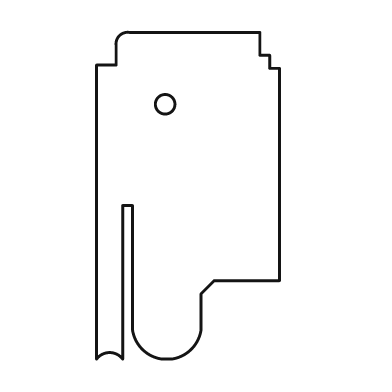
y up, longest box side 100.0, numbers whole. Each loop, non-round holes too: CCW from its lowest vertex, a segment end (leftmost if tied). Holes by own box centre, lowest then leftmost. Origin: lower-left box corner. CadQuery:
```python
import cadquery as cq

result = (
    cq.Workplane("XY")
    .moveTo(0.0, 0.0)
    .threePointArc((4.0, 2.0), (8.0, 0.0))
    .lineTo(8.0, 47.0)
    .lineTo(11.0, 47.0)
    .lineTo(11.0, 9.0)
    .threePointArc((14.0, 3.0), (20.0, 0.0))
    .lineTo(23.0, 0.0)
    .threePointArc((29.0, 3.0), (32.0, 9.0))
    .lineTo(32.0, 20.0)
    .lineTo(36.0, 24.0)
    .lineTo(56.0, 24.0)
    .lineTo(56.0, 89.0)
    .lineTo(53.0, 89.0)
    .lineTo(53.0, 93.0)
    .lineTo(50.0, 93.0)
    .lineTo(50.0, 100.0)
    .lineTo(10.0, 100.0)
    .threePointArc((7.0, 99.0), (6.0, 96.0))
    .lineTo(6.0, 90.0)
    .lineTo(0.0, 90.0)
    .close()
    .moveTo(21.0, 78.0)
    .circle(3.0)
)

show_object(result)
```